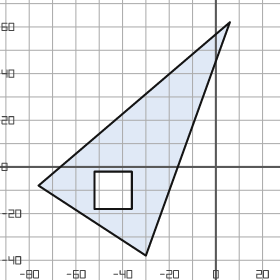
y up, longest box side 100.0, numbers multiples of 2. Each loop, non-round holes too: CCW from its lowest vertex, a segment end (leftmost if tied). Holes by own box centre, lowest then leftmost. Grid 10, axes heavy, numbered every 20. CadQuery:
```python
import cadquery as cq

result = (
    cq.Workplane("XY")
    .moveTo(-30.0, -38.0)
    .lineTo(6.0, 62.0)
    .lineTo(-76.0, -8.0)
    .close()
    .moveTo(-52.0, -18.0)
    .lineTo(-36.0, -18.0)
    .lineTo(-36.0, -2.0)
    .lineTo(-52.0, -2.0)
    .close()
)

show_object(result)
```